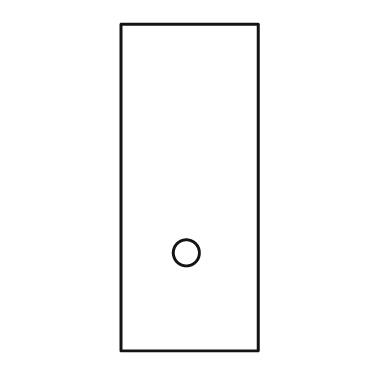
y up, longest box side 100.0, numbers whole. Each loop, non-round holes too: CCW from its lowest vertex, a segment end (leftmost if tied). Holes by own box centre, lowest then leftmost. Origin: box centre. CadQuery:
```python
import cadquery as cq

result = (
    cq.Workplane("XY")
    .moveTo(-21.0, -50.0)
    .lineTo(21.0, -50.0)
    .lineTo(21.0, 50.0)
    .lineTo(-21.0, 50.0)
    .close()
    .moveTo(-1.0, -20.0)
    .circle(4.0)
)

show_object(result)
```